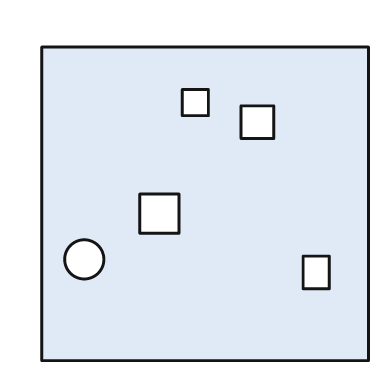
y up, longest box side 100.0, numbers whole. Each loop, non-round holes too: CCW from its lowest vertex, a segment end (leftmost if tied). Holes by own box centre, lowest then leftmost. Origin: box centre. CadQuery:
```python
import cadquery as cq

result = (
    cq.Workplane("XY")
    .moveTo(-50.0, -48.0)
    .lineTo(50.0, -48.0)
    .lineTo(50.0, 48.0)
    .lineTo(-50.0, 48.0)
    .close()
    .moveTo(30.0, -26.0)
    .lineTo(38.0, -26.0)
    .lineTo(38.0, -16.0)
    .lineTo(30.0, -16.0)
    .close()
    .moveTo(-37.0, -17.0)
    .circle(6.0)
    .moveTo(-20.0, -9.0)
    .lineTo(-8.0, -9.0)
    .lineTo(-8.0, 3.0)
    .lineTo(-20.0, 3.0)
    .close()
    .moveTo(11.0, 20.0)
    .lineTo(21.0, 20.0)
    .lineTo(21.0, 30.0)
    .lineTo(11.0, 30.0)
    .close()
    .moveTo(-7.0, 27.0)
    .lineTo(1.0, 27.0)
    .lineTo(1.0, 35.0)
    .lineTo(-7.0, 35.0)
    .close()
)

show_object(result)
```